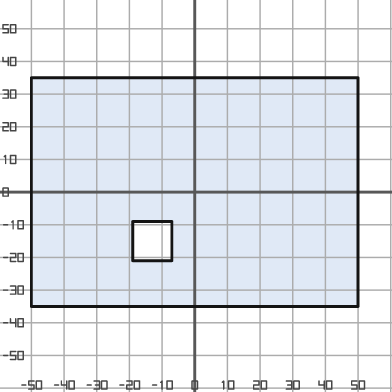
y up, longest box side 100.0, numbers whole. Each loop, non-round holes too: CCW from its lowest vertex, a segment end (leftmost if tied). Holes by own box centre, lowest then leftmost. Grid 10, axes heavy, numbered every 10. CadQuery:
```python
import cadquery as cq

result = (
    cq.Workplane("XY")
    .moveTo(-50.0, -35.0)
    .lineTo(50.0, -35.0)
    .lineTo(50.0, 35.0)
    .lineTo(-50.0, 35.0)
    .close()
    .moveTo(-19.0, -21.0)
    .lineTo(-7.0, -21.0)
    .lineTo(-7.0, -9.0)
    .lineTo(-19.0, -9.0)
    .close()
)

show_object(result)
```